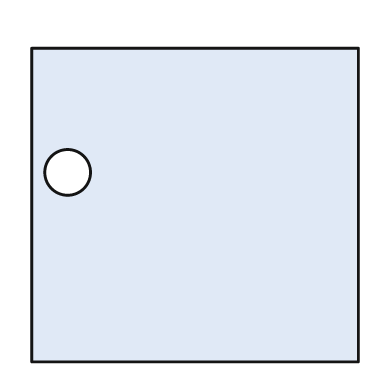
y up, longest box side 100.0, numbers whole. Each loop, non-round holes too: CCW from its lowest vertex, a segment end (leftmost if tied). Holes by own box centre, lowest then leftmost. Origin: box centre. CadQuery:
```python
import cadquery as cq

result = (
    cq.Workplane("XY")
    .moveTo(-50.0, -48.0)
    .lineTo(50.0, -48.0)
    .lineTo(50.0, 48.0)
    .lineTo(-50.0, 48.0)
    .close()
    .moveTo(-39.0, 10.0)
    .circle(7.0)
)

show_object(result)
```